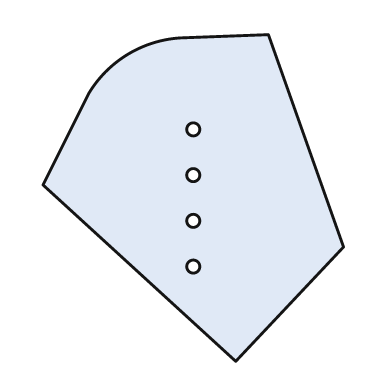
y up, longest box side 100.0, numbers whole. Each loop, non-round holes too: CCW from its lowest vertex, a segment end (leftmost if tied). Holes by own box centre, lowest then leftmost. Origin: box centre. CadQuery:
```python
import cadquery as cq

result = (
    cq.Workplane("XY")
    .moveTo(13.0, -50.0)
    .lineTo(46.0, -15.0)
    .lineTo(23.0, 50.0)
    .lineTo(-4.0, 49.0)
    .threePointArc((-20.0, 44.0), (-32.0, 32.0))
    .lineTo(-46.0, 4.0)
    .close()
    .moveTo(0.0, -21.0)
    .circle(2.0)
    .moveTo(0.0, -7.0)
    .circle(2.0)
    .moveTo(0.0, 7.0)
    .circle(2.0)
    .moveTo(0.0, 21.0)
    .circle(2.0)
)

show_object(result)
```